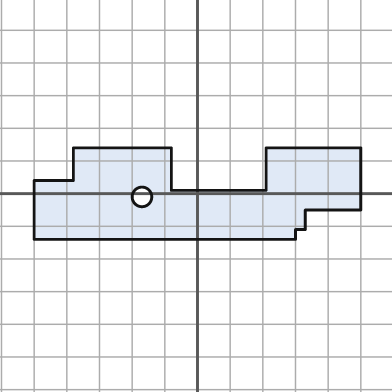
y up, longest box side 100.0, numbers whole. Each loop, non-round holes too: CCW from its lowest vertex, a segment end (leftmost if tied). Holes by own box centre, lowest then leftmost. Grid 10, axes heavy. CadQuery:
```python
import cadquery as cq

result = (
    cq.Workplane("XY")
    .moveTo(-50.0, -14.0)
    .lineTo(30.0, -14.0)
    .lineTo(30.0, -11.0)
    .lineTo(33.0, -11.0)
    .lineTo(33.0, -5.0)
    .lineTo(50.0, -5.0)
    .lineTo(50.0, 14.0)
    .lineTo(21.0, 14.0)
    .lineTo(21.0, 1.0)
    .lineTo(-8.0, 1.0)
    .lineTo(-8.0, 14.0)
    .lineTo(-38.0, 14.0)
    .lineTo(-38.0, 4.0)
    .lineTo(-50.0, 4.0)
    .close()
    .moveTo(-17.0, -1.0)
    .circle(3.0)
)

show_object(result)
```